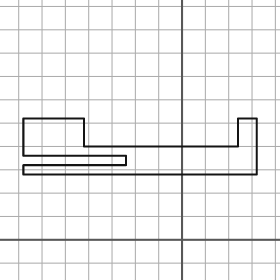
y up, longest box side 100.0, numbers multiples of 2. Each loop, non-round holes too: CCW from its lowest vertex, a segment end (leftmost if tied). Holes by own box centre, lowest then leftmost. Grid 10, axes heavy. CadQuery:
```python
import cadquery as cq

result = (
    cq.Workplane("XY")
    .moveTo(-68.0, 28.0)
    .lineTo(32.0, 28.0)
    .lineTo(32.0, 52.0)
    .lineTo(24.0, 52.0)
    .lineTo(24.0, 40.0)
    .lineTo(-42.0, 40.0)
    .lineTo(-42.0, 52.0)
    .lineTo(-68.0, 52.0)
    .lineTo(-68.0, 36.0)
    .lineTo(-24.0, 36.0)
    .lineTo(-24.0, 32.0)
    .lineTo(-68.0, 32.0)
    .close()
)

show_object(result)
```